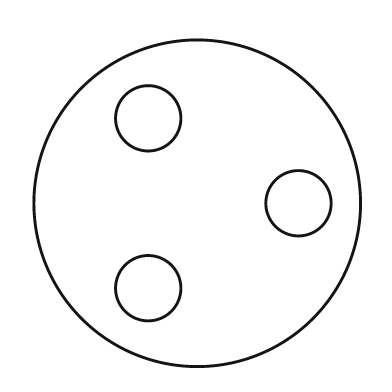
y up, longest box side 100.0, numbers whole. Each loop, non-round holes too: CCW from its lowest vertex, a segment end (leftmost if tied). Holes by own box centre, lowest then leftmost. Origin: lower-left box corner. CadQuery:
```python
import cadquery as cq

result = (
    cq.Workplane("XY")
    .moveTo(50.0, 50.0)
    .circle(50.0)
    .moveTo(35.0, 24.0)
    .circle(10.0)
    .moveTo(81.0, 50.0)
    .circle(10.0)
    .moveTo(35.0, 76.0)
    .circle(10.0)
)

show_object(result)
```